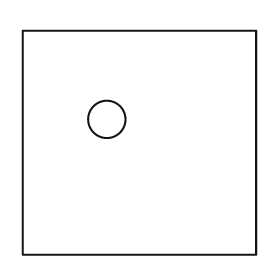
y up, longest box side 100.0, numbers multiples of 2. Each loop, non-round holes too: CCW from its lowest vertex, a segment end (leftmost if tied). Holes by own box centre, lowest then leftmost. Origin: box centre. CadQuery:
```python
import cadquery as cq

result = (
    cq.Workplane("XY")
    .moveTo(-50.0, -48.0)
    .lineTo(50.0, -48.0)
    .lineTo(50.0, 48.0)
    .lineTo(-50.0, 48.0)
    .close()
    .moveTo(-14.0, 10.0)
    .circle(8.0)
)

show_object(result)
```